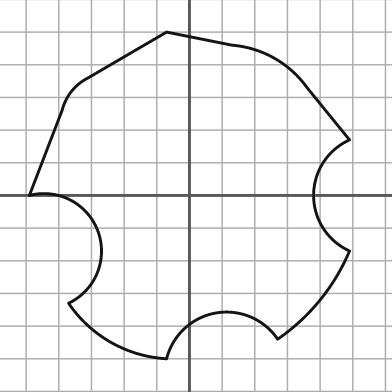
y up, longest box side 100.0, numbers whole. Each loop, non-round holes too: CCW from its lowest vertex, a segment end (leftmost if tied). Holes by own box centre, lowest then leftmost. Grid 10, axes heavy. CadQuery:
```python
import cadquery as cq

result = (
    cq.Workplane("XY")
    .moveTo(-7.0, -50.0)
    .threePointArc((8.0, -36.0), (27.0, -44.0))
    .threePointArc((40.0, -32.0), (49.0, -17.0))
    .threePointArc((38.0, 0.0), (49.0, 17.0))
    .lineTo(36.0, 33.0)
    .threePointArc((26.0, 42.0), (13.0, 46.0))
    .lineTo(-7.0, 50.0)
    .lineTo(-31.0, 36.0)
    .threePointArc((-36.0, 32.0), (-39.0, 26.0))
    .lineTo(-49.0, 0.0)
    .threePointArc((-28.0, -11.0), (-37.0, -33.0))
    .threePointArc((-24.0, -45.0), (-7.0, -50.0))
    .close()
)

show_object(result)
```